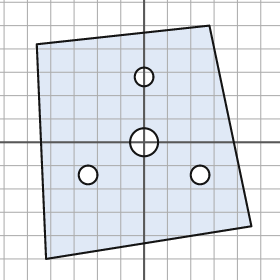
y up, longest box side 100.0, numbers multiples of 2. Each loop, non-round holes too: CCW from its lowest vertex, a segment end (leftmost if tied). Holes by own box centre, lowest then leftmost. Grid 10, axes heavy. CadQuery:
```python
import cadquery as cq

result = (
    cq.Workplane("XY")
    .moveTo(-42.0, -50.0)
    .lineTo(46.0, -36.0)
    .lineTo(28.0, 50.0)
    .lineTo(-46.0, 42.0)
    .close()
    .moveTo(-24.0, -14.0)
    .circle(4.0)
    .moveTo(24.0, -14.0)
    .circle(4.0)
    .moveTo(0.0, 0.0)
    .circle(6.0)
    .moveTo(0.0, 28.0)
    .circle(4.0)
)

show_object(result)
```